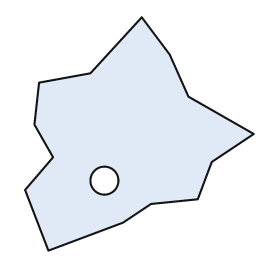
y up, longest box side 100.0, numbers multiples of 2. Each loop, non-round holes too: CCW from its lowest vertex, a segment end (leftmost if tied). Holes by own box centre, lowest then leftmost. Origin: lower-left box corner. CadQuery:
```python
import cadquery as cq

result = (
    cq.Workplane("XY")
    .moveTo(10.0, 0.0)
    .lineTo(42.0, 12.0)
    .lineTo(54.0, 20.0)
    .lineTo(74.0, 22.0)
    .lineTo(80.0, 38.0)
    .lineTo(98.0, 50.0)
    .lineTo(70.0, 66.0)
    .lineTo(62.0, 84.0)
    .lineTo(50.0, 100.0)
    .lineTo(28.0, 76.0)
    .lineTo(6.0, 72.0)
    .lineTo(4.0, 54.0)
    .lineTo(12.0, 40.0)
    .lineTo(0.0, 26.0)
    .close()
    .moveTo(34.0, 30.0)
    .circle(6.0)
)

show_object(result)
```